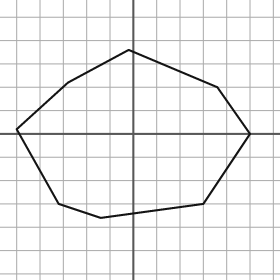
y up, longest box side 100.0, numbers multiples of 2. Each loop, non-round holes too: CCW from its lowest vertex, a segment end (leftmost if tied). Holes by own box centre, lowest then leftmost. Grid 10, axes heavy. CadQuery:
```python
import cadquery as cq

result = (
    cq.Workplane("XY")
    .moveTo(-14.0, -36.0)
    .lineTo(30.0, -30.0)
    .lineTo(50.0, 0.0)
    .lineTo(36.0, 20.0)
    .lineTo(-2.0, 36.0)
    .lineTo(-28.0, 22.0)
    .lineTo(-50.0, 2.0)
    .lineTo(-32.0, -30.0)
    .close()
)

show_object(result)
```